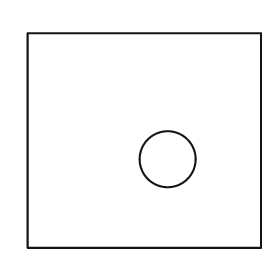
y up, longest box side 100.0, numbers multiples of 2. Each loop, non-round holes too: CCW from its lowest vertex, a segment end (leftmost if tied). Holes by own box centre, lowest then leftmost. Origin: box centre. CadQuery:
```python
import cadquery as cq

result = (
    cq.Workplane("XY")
    .moveTo(-50.0, -46.0)
    .lineTo(50.0, -46.0)
    .lineTo(50.0, 46.0)
    .lineTo(-50.0, 46.0)
    .close()
    .moveTo(10.0, -8.0)
    .circle(12.0)
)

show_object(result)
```